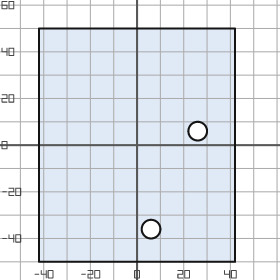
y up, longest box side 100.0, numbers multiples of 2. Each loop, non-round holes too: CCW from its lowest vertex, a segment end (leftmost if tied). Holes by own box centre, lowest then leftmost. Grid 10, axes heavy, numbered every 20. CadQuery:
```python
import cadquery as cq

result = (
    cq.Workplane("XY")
    .moveTo(-42.0, -50.0)
    .lineTo(42.0, -50.0)
    .lineTo(42.0, 50.0)
    .lineTo(-42.0, 50.0)
    .close()
    .moveTo(6.0, -36.0)
    .circle(4.0)
    .moveTo(26.0, 6.0)
    .circle(4.0)
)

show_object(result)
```